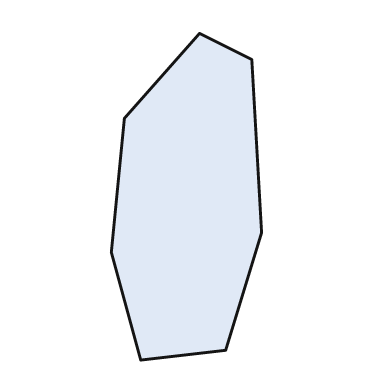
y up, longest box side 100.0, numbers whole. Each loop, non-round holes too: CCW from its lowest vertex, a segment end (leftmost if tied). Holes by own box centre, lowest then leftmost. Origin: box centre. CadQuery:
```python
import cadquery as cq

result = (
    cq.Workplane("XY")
    .moveTo(-14.0, -50.0)
    .lineTo(12.0, -47.0)
    .lineTo(23.0, -11.0)
    .lineTo(20.0, 42.0)
    .lineTo(4.0, 50.0)
    .lineTo(-19.0, 24.0)
    .lineTo(-23.0, -17.0)
    .close()
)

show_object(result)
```